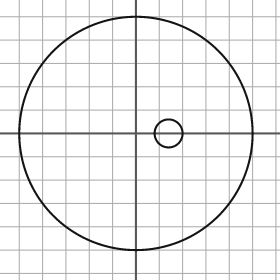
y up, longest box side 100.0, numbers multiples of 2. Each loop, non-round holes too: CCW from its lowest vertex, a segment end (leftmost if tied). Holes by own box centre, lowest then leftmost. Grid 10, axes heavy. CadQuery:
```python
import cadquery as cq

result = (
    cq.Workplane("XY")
    .moveTo(0.0, 0.0)
    .circle(50.0)
    .moveTo(14.0, 0.0)
    .circle(6.0)
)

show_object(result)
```